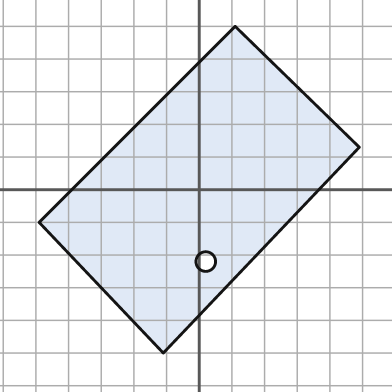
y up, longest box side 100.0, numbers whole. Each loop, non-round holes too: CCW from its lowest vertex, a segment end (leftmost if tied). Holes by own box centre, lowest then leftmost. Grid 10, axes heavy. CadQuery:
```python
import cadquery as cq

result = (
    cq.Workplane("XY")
    .moveTo(-11.0, -50.0)
    .lineTo(49.0, 13.0)
    .lineTo(11.0, 50.0)
    .lineTo(-49.0, -10.0)
    .close()
    .moveTo(2.0, -22.0)
    .circle(3.0)
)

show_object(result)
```